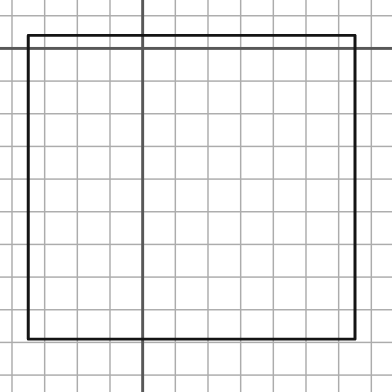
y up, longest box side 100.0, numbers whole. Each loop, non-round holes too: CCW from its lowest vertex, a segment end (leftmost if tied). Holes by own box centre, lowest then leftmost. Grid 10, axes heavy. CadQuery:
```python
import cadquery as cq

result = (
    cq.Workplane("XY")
    .moveTo(-35.0, -89.0)
    .lineTo(65.0, -89.0)
    .lineTo(65.0, 4.0)
    .lineTo(-35.0, 4.0)
    .close()
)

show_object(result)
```